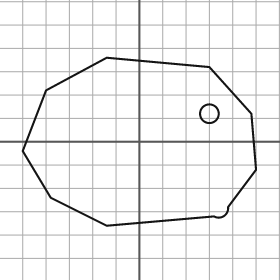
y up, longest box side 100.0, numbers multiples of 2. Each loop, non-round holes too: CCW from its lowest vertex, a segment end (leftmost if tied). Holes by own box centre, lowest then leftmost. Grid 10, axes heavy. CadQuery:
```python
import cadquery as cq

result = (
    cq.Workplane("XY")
    .moveTo(-14.0, -36.0)
    .lineTo(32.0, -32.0)
    .threePointArc((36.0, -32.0), (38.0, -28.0))
    .lineTo(50.0, -12.0)
    .lineTo(48.0, 12.0)
    .lineTo(30.0, 32.0)
    .lineTo(-14.0, 36.0)
    .lineTo(-40.0, 22.0)
    .lineTo(-50.0, -4.0)
    .lineTo(-38.0, -24.0)
    .close()
    .moveTo(30.0, 12.0)
    .circle(4.0)
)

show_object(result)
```